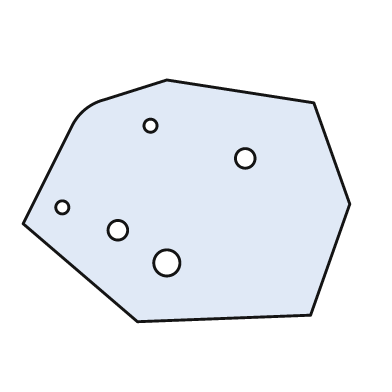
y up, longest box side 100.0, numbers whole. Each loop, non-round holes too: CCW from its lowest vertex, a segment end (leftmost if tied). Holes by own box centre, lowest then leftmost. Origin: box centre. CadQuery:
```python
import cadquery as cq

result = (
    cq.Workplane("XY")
    .moveTo(-15.0, -37.0)
    .lineTo(38.0, -35.0)
    .lineTo(50.0, -1.0)
    .lineTo(39.0, 30.0)
    .lineTo(-6.0, 37.0)
    .lineTo(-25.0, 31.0)
    .threePointArc((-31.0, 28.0), (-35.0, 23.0))
    .lineTo(-50.0, -7.0)
    .close()
    .moveTo(-6.0, -19.0)
    .circle(4.0)
    .moveTo(-21.0, -9.0)
    .circle(3.0)
    .moveTo(-38.0, -2.0)
    .circle(2.0)
    .moveTo(18.0, 13.0)
    .circle(3.0)
    .moveTo(-11.0, 23.0)
    .circle(2.0)
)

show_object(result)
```